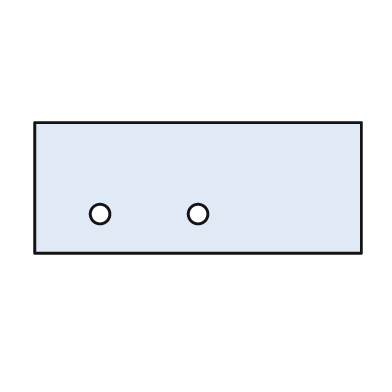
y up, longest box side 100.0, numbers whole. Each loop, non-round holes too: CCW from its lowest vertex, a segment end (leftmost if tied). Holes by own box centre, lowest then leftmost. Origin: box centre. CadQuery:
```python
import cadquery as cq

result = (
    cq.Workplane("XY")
    .moveTo(-50.0, -20.0)
    .lineTo(50.0, -20.0)
    .lineTo(50.0, 20.0)
    .lineTo(-50.0, 20.0)
    .close()
    .moveTo(-30.0, -8.0)
    .circle(3.0)
    .moveTo(0.0, -8.0)
    .circle(3.0)
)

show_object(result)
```